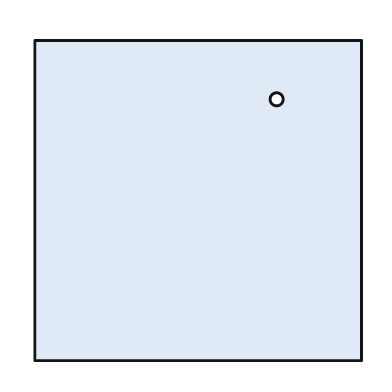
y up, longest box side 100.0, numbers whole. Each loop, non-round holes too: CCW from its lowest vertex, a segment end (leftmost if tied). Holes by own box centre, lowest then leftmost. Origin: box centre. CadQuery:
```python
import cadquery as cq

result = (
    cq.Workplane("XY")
    .moveTo(-50.0, -49.0)
    .lineTo(50.0, -49.0)
    .lineTo(50.0, 49.0)
    .lineTo(-50.0, 49.0)
    .close()
    .moveTo(24.0, 31.0)
    .circle(2.0)
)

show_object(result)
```